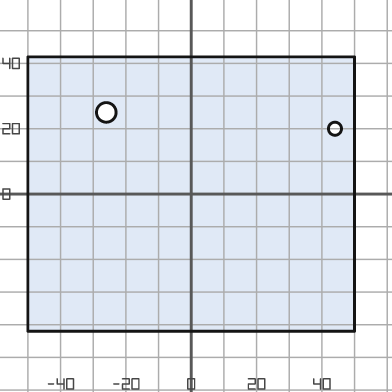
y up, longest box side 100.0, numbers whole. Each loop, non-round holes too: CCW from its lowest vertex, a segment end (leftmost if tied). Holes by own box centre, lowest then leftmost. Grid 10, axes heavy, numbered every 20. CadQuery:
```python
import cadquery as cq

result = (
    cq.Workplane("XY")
    .moveTo(-50.0, -42.0)
    .lineTo(50.0, -42.0)
    .lineTo(50.0, 42.0)
    .lineTo(-50.0, 42.0)
    .close()
    .moveTo(44.0, 20.0)
    .circle(2.0)
    .moveTo(-26.0, 25.0)
    .circle(3.0)
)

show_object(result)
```